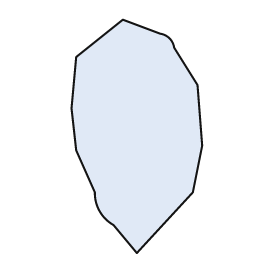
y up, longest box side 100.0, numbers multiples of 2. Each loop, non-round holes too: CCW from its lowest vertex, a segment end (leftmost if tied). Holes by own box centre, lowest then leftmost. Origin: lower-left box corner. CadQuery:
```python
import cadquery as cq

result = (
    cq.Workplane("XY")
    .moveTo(28.0, 0.0)
    .lineTo(52.0, 26.0)
    .lineTo(56.0, 46.0)
    .lineTo(54.0, 72.0)
    .lineTo(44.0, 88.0)
    .threePointArc((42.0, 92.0), (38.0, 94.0))
    .lineTo(22.0, 100.0)
    .lineTo(2.0, 84.0)
    .lineTo(0.0, 62.0)
    .lineTo(2.0, 44.0)
    .lineTo(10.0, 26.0)
    .threePointArc((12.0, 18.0), (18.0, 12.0))
    .close()
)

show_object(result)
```